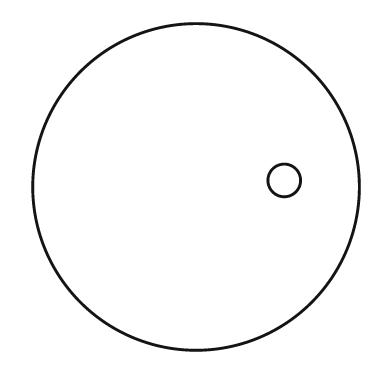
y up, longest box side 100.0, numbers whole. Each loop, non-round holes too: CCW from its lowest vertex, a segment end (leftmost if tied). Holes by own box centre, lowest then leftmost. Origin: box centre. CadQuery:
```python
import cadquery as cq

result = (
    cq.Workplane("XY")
    .moveTo(0.0, 0.0)
    .circle(50.0)
    .moveTo(27.0, 2.0)
    .circle(5.0)
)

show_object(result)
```